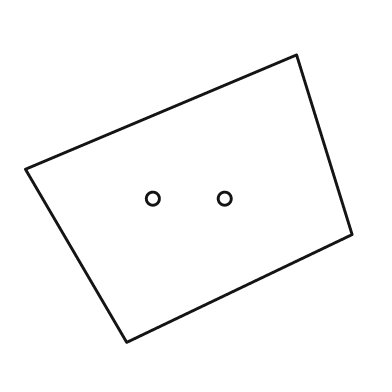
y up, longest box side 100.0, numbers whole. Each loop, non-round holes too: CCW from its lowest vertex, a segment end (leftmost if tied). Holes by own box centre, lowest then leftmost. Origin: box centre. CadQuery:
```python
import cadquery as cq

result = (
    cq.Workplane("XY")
    .moveTo(-19.0, -44.0)
    .lineTo(50.0, -11.0)
    .lineTo(33.0, 44.0)
    .lineTo(-50.0, 9.0)
    .close()
    .moveTo(-11.0, 0.0)
    .circle(2.0)
    .moveTo(11.0, 0.0)
    .circle(2.0)
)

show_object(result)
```